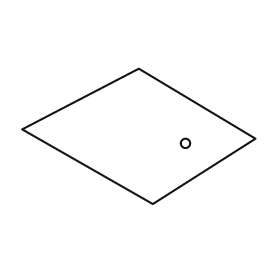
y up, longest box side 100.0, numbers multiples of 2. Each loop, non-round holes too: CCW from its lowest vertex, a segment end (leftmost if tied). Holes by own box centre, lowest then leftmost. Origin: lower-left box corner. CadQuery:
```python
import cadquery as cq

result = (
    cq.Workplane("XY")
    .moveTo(56.0, 0.0)
    .lineTo(100.0, 28.0)
    .lineTo(50.0, 58.0)
    .lineTo(0.0, 32.0)
    .close()
    .moveTo(70.0, 26.0)
    .circle(2.0)
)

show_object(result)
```